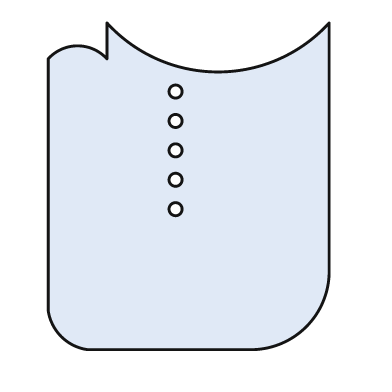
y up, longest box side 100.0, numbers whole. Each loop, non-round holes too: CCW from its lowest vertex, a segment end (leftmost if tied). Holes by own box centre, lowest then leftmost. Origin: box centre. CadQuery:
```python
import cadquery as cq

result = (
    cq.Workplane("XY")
    .moveTo(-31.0, -50.0)
    .lineTo(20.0, -50.0)
    .threePointArc((36.0, -43.0), (43.0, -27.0))
    .lineTo(43.0, 50.0)
    .threePointArc((9.0, 35.0), (-25.0, 50.0))
    .lineTo(-25.0, 39.0)
    .threePointArc((-34.0, 43.0), (-43.0, 39.0))
    .lineTo(-43.0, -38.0)
    .threePointArc((-39.0, -46.0), (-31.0, -50.0))
    .close()
    .moveTo(-4.0, -7.0)
    .circle(2.0)
    .moveTo(-4.0, 2.0)
    .circle(2.0)
    .moveTo(-4.0, 11.0)
    .circle(2.0)
    .moveTo(-4.0, 20.0)
    .circle(2.0)
    .moveTo(-4.0, 29.0)
    .circle(2.0)
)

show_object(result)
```